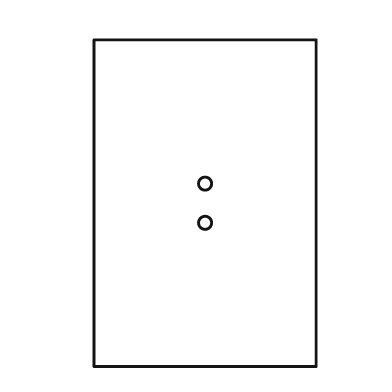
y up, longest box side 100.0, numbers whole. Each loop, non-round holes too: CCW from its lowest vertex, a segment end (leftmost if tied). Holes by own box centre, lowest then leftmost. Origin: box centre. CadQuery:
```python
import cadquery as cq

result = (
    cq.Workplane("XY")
    .moveTo(-34.0, -50.0)
    .lineTo(34.0, -50.0)
    .lineTo(34.0, 50.0)
    .lineTo(-34.0, 50.0)
    .close()
    .moveTo(0.0, -6.0)
    .circle(2.0)
    .moveTo(0.0, 6.0)
    .circle(2.0)
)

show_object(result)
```